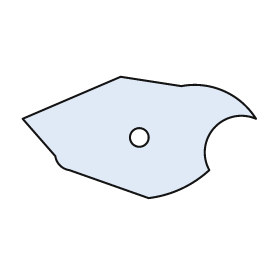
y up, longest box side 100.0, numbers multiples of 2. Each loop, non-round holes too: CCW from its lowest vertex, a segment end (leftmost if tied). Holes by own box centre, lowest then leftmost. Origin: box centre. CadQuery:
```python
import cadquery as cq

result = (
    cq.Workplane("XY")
    .moveTo(4.0, -26.0)
    .threePointArc((18.0, -22.0), (30.0, -14.0))
    .threePointArc((32.0, 4.0), (50.0, 8.0))
    .threePointArc((36.0, 20.0), (18.0, 22.0))
    .lineTo(-8.0, 26.0)
    .lineTo(-50.0, 8.0)
    .lineTo(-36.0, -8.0)
    .threePointArc((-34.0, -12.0), (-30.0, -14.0))
    .close()
    .moveTo(0.0, 0.0)
    .circle(4.0)
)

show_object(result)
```